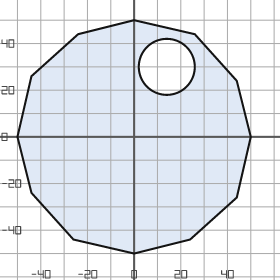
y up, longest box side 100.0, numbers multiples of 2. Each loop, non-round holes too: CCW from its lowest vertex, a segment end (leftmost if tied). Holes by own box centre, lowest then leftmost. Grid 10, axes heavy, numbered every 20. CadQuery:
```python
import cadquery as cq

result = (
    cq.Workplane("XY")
    .moveTo(0.0, -50.0)
    .lineTo(24.0, -44.0)
    .lineTo(44.0, -26.0)
    .lineTo(50.0, 0.0)
    .lineTo(44.0, 24.0)
    .lineTo(26.0, 44.0)
    .lineTo(0.0, 50.0)
    .lineTo(-24.0, 44.0)
    .lineTo(-44.0, 26.0)
    .lineTo(-50.0, 0.0)
    .lineTo(-44.0, -24.0)
    .lineTo(-26.0, -44.0)
    .close()
    .moveTo(14.0, 30.0)
    .circle(12.0)
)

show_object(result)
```